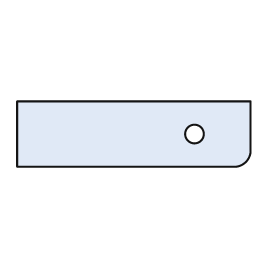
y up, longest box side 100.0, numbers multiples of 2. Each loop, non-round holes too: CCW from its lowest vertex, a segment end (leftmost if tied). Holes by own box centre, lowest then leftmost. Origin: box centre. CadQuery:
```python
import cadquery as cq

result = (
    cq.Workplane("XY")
    .moveTo(-50.0, -14.0)
    .lineTo(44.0, -14.0)
    .threePointArc((48.0, -12.0), (50.0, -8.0))
    .lineTo(50.0, 14.0)
    .lineTo(-50.0, 14.0)
    .close()
    .moveTo(26.0, 0.0)
    .circle(4.0)
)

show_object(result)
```